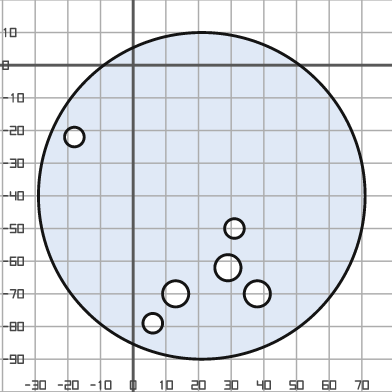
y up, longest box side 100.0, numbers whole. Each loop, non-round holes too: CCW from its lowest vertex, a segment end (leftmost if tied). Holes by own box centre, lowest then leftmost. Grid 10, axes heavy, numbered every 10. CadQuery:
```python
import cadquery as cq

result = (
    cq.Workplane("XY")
    .moveTo(21.0, -40.0)
    .circle(50.0)
    .moveTo(6.0, -79.0)
    .circle(3.0)
    .moveTo(13.0, -70.0)
    .circle(4.0)
    .moveTo(38.0, -70.0)
    .circle(4.0)
    .moveTo(29.0, -62.0)
    .circle(4.0)
    .moveTo(31.0, -50.0)
    .circle(3.0)
    .moveTo(-18.0, -22.0)
    .circle(3.0)
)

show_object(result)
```